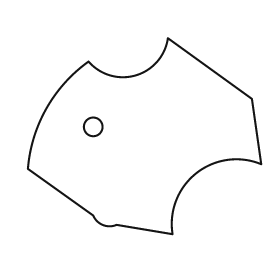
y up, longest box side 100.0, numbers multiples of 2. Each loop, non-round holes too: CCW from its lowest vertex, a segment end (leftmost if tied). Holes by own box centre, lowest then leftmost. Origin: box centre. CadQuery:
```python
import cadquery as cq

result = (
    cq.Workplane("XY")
    .moveTo(12.0, -42.0)
    .threePointArc((22.0, -16.0), (50.0, -12.0))
    .lineTo(46.0, 16.0)
    .lineTo(10.0, 42.0)
    .threePointArc((-4.0, 26.0), (-24.0, 32.0))
    .threePointArc((-42.0, 12.0), (-50.0, -14.0))
    .lineTo(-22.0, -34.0)
    .threePointArc((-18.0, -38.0), (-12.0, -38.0))
    .close()
    .moveTo(-22.0, 4.0)
    .circle(4.0)
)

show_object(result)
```